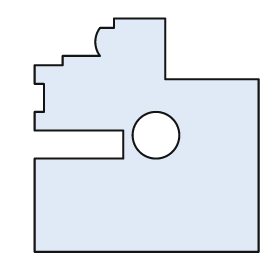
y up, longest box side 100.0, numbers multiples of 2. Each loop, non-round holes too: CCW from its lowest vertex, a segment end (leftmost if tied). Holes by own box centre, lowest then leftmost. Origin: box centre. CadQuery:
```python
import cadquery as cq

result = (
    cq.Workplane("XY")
    .moveTo(-48.0, -50.0)
    .lineTo(48.0, -50.0)
    .lineTo(48.0, 24.0)
    .lineTo(8.0, 24.0)
    .lineTo(8.0, 50.0)
    .lineTo(-14.0, 50.0)
    .lineTo(-14.0, 46.0)
    .lineTo(-20.0, 46.0)
    .threePointArc((-22.0, 40.0), (-20.0, 34.0))
    .lineTo(-36.0, 34.0)
    .lineTo(-36.0, 30.0)
    .lineTo(-48.0, 30.0)
    .lineTo(-48.0, 22.0)
    .lineTo(-44.0, 22.0)
    .lineTo(-44.0, 10.0)
    .lineTo(-48.0, 10.0)
    .lineTo(-48.0, 2.0)
    .lineTo(-10.0, 2.0)
    .lineTo(-10.0, -10.0)
    .lineTo(-48.0, -10.0)
    .close()
    .moveTo(4.0, 0.0)
    .circle(10.0)
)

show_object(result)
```